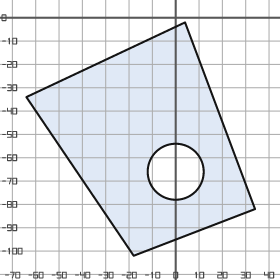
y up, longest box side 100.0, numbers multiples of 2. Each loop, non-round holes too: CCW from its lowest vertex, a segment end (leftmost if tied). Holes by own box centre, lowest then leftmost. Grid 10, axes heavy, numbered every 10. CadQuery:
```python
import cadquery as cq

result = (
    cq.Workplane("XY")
    .moveTo(-18.0, -102.0)
    .lineTo(34.0, -82.0)
    .lineTo(4.0, -2.0)
    .lineTo(-64.0, -34.0)
    .close()
    .moveTo(0.0, -66.0)
    .circle(12.0)
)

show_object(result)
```